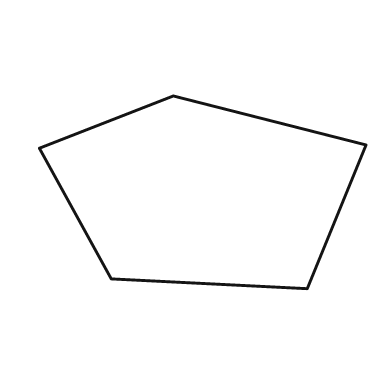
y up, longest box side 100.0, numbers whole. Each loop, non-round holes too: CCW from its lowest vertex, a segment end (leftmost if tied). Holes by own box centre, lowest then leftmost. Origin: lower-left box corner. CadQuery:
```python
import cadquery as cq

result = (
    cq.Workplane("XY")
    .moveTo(82.0, 0.0)
    .lineTo(100.0, 44.0)
    .lineTo(41.0, 59.0)
    .lineTo(0.0, 43.0)
    .lineTo(22.0, 3.0)
    .close()
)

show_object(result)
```